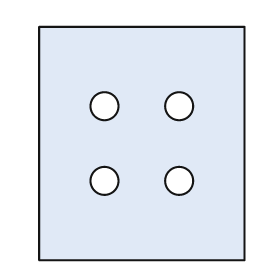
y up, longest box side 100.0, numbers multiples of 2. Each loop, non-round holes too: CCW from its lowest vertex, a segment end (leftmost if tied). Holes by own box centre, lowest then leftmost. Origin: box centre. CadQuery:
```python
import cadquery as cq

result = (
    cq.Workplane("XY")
    .moveTo(-44.0, -50.0)
    .lineTo(44.0, -50.0)
    .lineTo(44.0, 50.0)
    .lineTo(-44.0, 50.0)
    .close()
    .moveTo(-16.0, -16.0)
    .circle(6.0)
    .moveTo(16.0, -16.0)
    .circle(6.0)
    .moveTo(-16.0, 16.0)
    .circle(6.0)
    .moveTo(16.0, 16.0)
    .circle(6.0)
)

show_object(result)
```